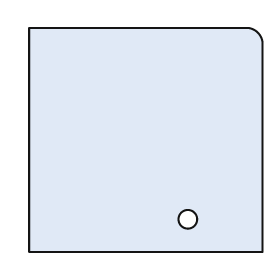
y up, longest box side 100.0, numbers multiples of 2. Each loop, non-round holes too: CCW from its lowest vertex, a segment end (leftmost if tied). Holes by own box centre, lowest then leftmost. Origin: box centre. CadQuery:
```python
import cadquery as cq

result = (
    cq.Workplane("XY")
    .moveTo(-50.0, -48.0)
    .lineTo(50.0, -48.0)
    .lineTo(50.0, 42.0)
    .threePointArc((48.0, 46.0), (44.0, 48.0))
    .lineTo(-50.0, 48.0)
    .close()
    .moveTo(18.0, -34.0)
    .circle(4.0)
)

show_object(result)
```